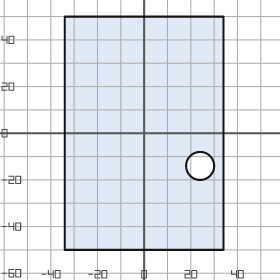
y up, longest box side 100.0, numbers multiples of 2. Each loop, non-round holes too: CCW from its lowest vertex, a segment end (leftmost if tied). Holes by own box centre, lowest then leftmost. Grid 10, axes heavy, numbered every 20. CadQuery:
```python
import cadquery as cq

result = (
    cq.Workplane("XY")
    .moveTo(-34.0, -50.0)
    .lineTo(34.0, -50.0)
    .lineTo(34.0, 50.0)
    .lineTo(-34.0, 50.0)
    .close()
    .moveTo(24.0, -14.0)
    .circle(6.0)
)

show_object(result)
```